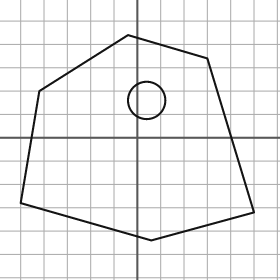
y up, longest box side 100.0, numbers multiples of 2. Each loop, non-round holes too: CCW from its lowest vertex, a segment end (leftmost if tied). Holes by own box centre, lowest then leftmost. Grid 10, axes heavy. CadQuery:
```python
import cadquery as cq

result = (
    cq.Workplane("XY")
    .moveTo(6.0, -44.0)
    .lineTo(50.0, -32.0)
    .lineTo(30.0, 34.0)
    .lineTo(-4.0, 44.0)
    .lineTo(-42.0, 20.0)
    .lineTo(-50.0, -28.0)
    .close()
    .moveTo(4.0, 16.0)
    .circle(8.0)
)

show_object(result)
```